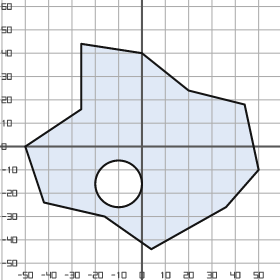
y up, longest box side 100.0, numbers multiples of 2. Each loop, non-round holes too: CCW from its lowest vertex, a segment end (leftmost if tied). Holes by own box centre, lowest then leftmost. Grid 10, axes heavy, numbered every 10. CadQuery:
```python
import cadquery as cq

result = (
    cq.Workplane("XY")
    .moveTo(4.0, -44.0)
    .lineTo(36.0, -26.0)
    .lineTo(50.0, -10.0)
    .lineTo(44.0, 18.0)
    .lineTo(20.0, 24.0)
    .lineTo(0.0, 40.0)
    .lineTo(-26.0, 44.0)
    .lineTo(-26.0, 16.0)
    .lineTo(-50.0, 0.0)
    .lineTo(-42.0, -24.0)
    .lineTo(-16.0, -30.0)
    .close()
    .moveTo(-10.0, -16.0)
    .circle(10.0)
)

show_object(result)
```